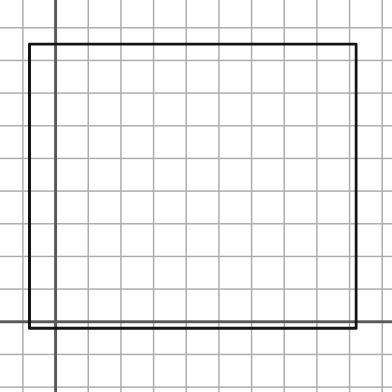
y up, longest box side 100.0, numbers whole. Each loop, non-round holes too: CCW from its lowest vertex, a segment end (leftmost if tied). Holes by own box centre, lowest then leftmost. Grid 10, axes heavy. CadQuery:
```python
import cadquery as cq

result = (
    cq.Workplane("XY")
    .moveTo(-8.0, -2.0)
    .lineTo(92.0, -2.0)
    .lineTo(92.0, 85.0)
    .lineTo(-8.0, 85.0)
    .close()
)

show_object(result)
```